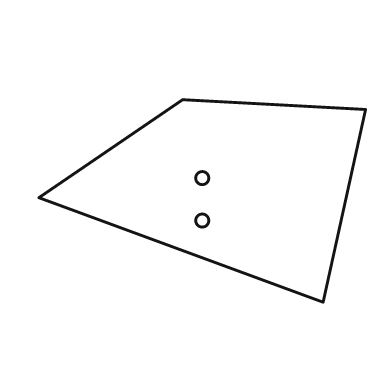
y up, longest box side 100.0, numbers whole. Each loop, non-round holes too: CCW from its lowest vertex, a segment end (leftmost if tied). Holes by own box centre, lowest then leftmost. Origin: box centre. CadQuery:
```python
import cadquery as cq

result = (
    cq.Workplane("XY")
    .moveTo(37.0, -31.0)
    .lineTo(50.0, 28.0)
    .lineTo(-6.0, 31.0)
    .lineTo(-50.0, 1.0)
    .close()
    .moveTo(0.0, -6.0)
    .circle(2.0)
    .moveTo(0.0, 7.0)
    .circle(2.0)
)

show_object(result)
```